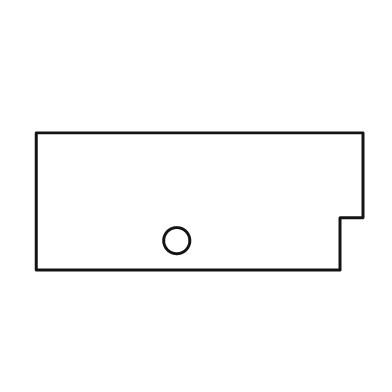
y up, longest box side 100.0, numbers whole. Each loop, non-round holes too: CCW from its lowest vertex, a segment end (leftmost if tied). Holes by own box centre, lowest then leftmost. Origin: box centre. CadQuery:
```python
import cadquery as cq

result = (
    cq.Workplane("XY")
    .moveTo(-50.0, -21.0)
    .lineTo(43.0, -21.0)
    .lineTo(43.0, -5.0)
    .lineTo(50.0, -5.0)
    .lineTo(50.0, 21.0)
    .lineTo(-50.0, 21.0)
    .close()
    .moveTo(-7.0, -12.0)
    .circle(4.0)
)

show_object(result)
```